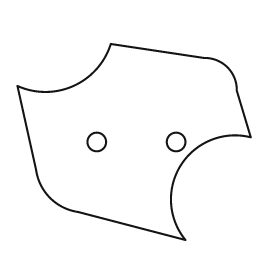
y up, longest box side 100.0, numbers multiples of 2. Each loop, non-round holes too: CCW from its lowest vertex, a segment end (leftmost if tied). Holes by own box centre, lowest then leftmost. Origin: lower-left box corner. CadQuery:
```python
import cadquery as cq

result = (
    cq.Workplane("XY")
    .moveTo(72.0, 0.0)
    .threePointArc((70.0, 32.0), (100.0, 44.0))
    .lineTo(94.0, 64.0)
    .threePointArc((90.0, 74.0), (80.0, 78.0))
    .lineTo(40.0, 84.0)
    .threePointArc((24.0, 66.0), (0.0, 66.0))
    .lineTo(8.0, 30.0)
    .threePointArc((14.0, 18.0), (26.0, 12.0))
    .close()
    .moveTo(34.0, 42.0)
    .circle(4.0)
    .moveTo(68.0, 42.0)
    .circle(4.0)
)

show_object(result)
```